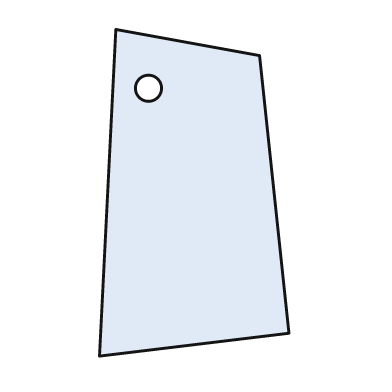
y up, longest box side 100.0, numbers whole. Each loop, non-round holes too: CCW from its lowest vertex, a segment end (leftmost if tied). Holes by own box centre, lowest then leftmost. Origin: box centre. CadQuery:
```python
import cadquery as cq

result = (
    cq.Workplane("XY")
    .moveTo(-29.0, -50.0)
    .lineTo(29.0, -43.0)
    .lineTo(20.0, 42.0)
    .lineTo(-24.0, 50.0)
    .close()
    .moveTo(-14.0, 32.0)
    .circle(4.0)
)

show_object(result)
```